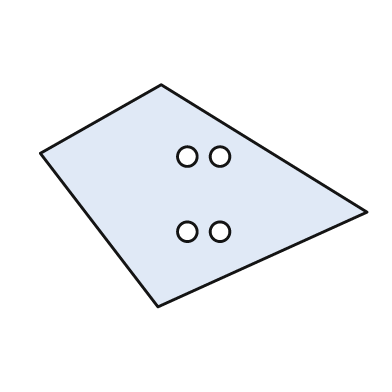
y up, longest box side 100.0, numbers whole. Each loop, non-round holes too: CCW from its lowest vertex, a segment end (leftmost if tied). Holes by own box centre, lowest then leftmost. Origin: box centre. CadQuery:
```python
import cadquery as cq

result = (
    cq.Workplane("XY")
    .moveTo(-14.0, -34.0)
    .lineTo(50.0, -5.0)
    .lineTo(-13.0, 34.0)
    .lineTo(-50.0, 13.0)
    .close()
    .moveTo(-5.0, -11.0)
    .circle(3.0)
    .moveTo(5.0, -11.0)
    .circle(3.0)
    .moveTo(-5.0, 12.0)
    .circle(3.0)
    .moveTo(5.0, 12.0)
    .circle(3.0)
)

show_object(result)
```